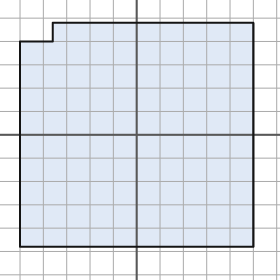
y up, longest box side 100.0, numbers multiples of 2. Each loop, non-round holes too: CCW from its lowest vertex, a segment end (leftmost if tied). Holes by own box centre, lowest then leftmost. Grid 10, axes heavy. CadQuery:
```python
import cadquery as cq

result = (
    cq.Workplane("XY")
    .moveTo(-50.0, -48.0)
    .lineTo(50.0, -48.0)
    .lineTo(50.0, 48.0)
    .lineTo(-36.0, 48.0)
    .lineTo(-36.0, 40.0)
    .lineTo(-50.0, 40.0)
    .close()
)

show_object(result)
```